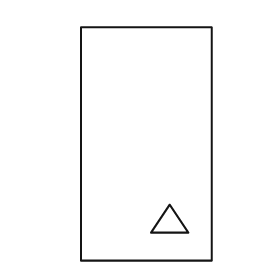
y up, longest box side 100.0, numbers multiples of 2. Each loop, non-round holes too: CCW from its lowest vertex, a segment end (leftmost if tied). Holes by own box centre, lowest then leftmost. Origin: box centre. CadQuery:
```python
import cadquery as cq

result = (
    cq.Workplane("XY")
    .moveTo(-28.0, -50.0)
    .lineTo(28.0, -50.0)
    .lineTo(28.0, 50.0)
    .lineTo(-28.0, 50.0)
    .close()
    .moveTo(2.0, -38.0)
    .lineTo(18.0, -38.0)
    .lineTo(10.0, -26.0)
    .close()
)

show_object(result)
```